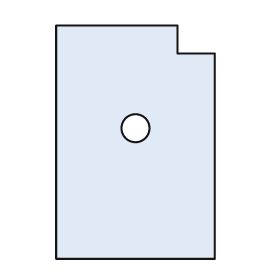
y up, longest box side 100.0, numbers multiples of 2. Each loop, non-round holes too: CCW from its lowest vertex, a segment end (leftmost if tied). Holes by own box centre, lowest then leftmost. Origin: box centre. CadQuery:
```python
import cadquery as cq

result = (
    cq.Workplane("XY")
    .moveTo(-34.0, -50.0)
    .lineTo(34.0, -50.0)
    .lineTo(34.0, 38.0)
    .lineTo(18.0, 38.0)
    .lineTo(18.0, 50.0)
    .lineTo(-34.0, 50.0)
    .close()
    .moveTo(0.0, 6.0)
    .circle(6.0)
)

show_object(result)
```